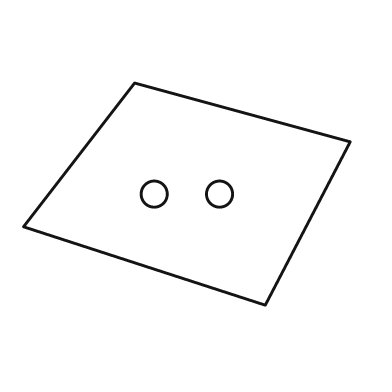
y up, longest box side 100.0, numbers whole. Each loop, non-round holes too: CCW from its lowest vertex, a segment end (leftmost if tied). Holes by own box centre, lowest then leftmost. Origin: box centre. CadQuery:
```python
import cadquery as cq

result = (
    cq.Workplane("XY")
    .moveTo(24.0, -34.0)
    .lineTo(50.0, 16.0)
    .lineTo(-16.0, 34.0)
    .lineTo(-50.0, -10.0)
    .close()
    .moveTo(-10.0, 0.0)
    .circle(4.0)
    .moveTo(10.0, 0.0)
    .circle(4.0)
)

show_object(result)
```